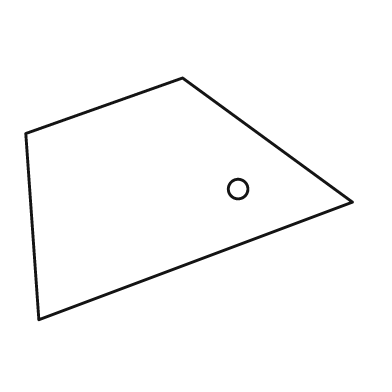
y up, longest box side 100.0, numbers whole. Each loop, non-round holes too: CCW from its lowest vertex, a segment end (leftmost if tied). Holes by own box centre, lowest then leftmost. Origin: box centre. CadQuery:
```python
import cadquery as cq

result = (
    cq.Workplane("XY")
    .moveTo(-46.0, -37.0)
    .lineTo(50.0, -1.0)
    .lineTo(-2.0, 37.0)
    .lineTo(-50.0, 20.0)
    .close()
    .moveTo(15.0, 3.0)
    .circle(3.0)
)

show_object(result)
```